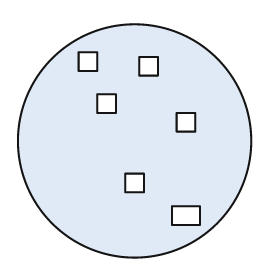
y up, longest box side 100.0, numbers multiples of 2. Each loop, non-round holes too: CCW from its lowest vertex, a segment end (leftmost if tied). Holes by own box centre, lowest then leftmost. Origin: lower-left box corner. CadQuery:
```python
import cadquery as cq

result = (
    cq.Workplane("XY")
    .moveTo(50.0, 50.0)
    .circle(50.0)
    .moveTo(66.0, 14.0)
    .lineTo(78.0, 14.0)
    .lineTo(78.0, 22.0)
    .lineTo(66.0, 22.0)
    .close()
    .moveTo(46.0, 28.0)
    .lineTo(54.0, 28.0)
    .lineTo(54.0, 36.0)
    .lineTo(46.0, 36.0)
    .close()
    .moveTo(68.0, 54.0)
    .lineTo(76.0, 54.0)
    .lineTo(76.0, 62.0)
    .lineTo(68.0, 62.0)
    .close()
    .moveTo(34.0, 62.0)
    .lineTo(42.0, 62.0)
    .lineTo(42.0, 70.0)
    .lineTo(34.0, 70.0)
    .close()
    .moveTo(52.0, 78.0)
    .lineTo(60.0, 78.0)
    .lineTo(60.0, 86.0)
    .lineTo(52.0, 86.0)
    .close()
    .moveTo(26.0, 80.0)
    .lineTo(34.0, 80.0)
    .lineTo(34.0, 88.0)
    .lineTo(26.0, 88.0)
    .close()
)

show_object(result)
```